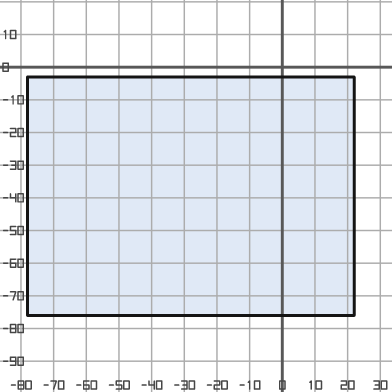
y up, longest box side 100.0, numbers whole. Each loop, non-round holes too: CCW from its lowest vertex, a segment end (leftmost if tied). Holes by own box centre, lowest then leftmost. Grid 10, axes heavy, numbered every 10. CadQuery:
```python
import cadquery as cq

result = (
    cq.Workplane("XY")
    .moveTo(-78.0, -76.0)
    .lineTo(22.0, -76.0)
    .lineTo(22.0, -3.0)
    .lineTo(-78.0, -3.0)
    .close()
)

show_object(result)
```